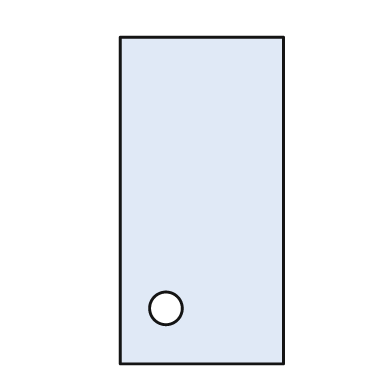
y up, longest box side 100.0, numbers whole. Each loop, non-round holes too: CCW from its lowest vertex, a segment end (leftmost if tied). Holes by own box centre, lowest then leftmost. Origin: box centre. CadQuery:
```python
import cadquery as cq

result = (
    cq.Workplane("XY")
    .moveTo(-25.0, -50.0)
    .lineTo(25.0, -50.0)
    .lineTo(25.0, 50.0)
    .lineTo(-25.0, 50.0)
    .close()
    .moveTo(-11.0, -33.0)
    .circle(5.0)
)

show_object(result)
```